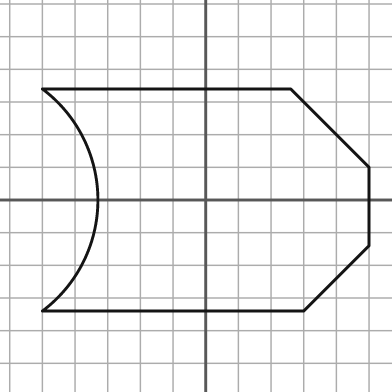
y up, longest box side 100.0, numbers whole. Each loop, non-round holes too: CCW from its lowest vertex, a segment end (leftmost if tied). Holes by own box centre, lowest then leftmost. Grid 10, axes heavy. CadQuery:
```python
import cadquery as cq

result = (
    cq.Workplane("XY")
    .moveTo(-50.0, -34.0)
    .lineTo(30.0, -34.0)
    .lineTo(50.0, -14.0)
    .lineTo(50.0, 10.0)
    .lineTo(26.0, 34.0)
    .lineTo(-50.0, 34.0)
    .threePointArc((-33.0, 0.0), (-50.0, -34.0))
    .close()
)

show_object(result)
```